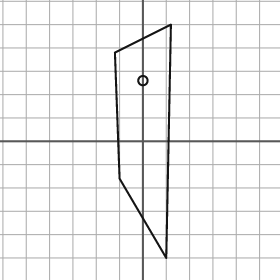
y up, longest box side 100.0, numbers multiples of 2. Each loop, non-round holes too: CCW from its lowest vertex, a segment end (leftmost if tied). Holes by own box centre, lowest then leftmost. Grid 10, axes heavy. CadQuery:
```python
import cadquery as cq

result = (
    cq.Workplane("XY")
    .moveTo(10.0, -50.0)
    .lineTo(12.0, 50.0)
    .lineTo(-12.0, 38.0)
    .lineTo(-10.0, -16.0)
    .close()
    .moveTo(0.0, 26.0)
    .circle(2.0)
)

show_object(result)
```